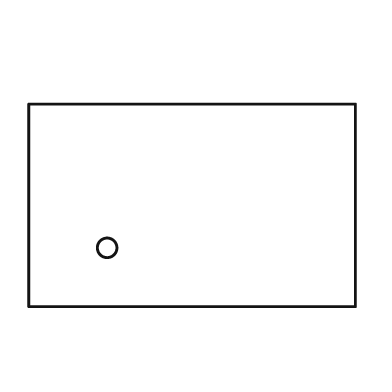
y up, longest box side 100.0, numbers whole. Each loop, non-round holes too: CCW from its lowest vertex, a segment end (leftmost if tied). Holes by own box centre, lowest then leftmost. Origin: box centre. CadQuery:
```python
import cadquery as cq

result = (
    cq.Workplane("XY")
    .moveTo(-50.0, -31.0)
    .lineTo(50.0, -31.0)
    .lineTo(50.0, 31.0)
    .lineTo(-50.0, 31.0)
    .close()
    .moveTo(-26.0, -13.0)
    .circle(3.0)
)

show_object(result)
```